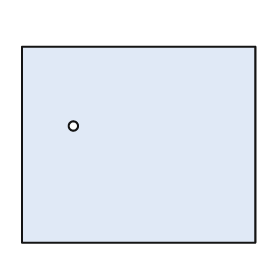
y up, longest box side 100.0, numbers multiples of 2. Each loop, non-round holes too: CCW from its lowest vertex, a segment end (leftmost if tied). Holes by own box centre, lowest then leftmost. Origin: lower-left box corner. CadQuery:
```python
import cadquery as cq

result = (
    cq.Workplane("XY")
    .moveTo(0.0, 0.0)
    .lineTo(100.0, 0.0)
    .lineTo(100.0, 84.0)
    .lineTo(0.0, 84.0)
    .close()
    .moveTo(22.0, 50.0)
    .circle(2.0)
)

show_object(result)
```